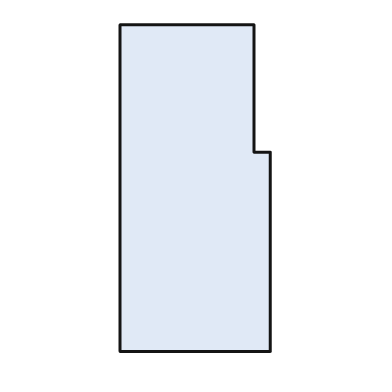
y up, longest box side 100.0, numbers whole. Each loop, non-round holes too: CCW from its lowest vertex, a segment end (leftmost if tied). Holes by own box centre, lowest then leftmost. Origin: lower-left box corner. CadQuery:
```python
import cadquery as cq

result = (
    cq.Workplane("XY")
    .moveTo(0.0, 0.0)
    .lineTo(46.0, 0.0)
    .lineTo(46.0, 61.0)
    .lineTo(41.0, 61.0)
    .lineTo(41.0, 100.0)
    .lineTo(0.0, 100.0)
    .close()
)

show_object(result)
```